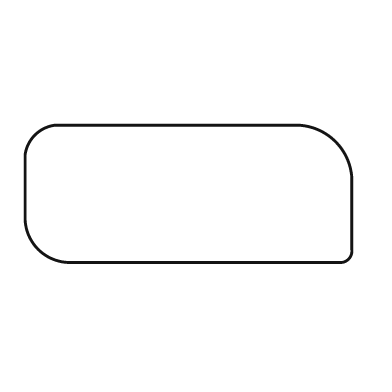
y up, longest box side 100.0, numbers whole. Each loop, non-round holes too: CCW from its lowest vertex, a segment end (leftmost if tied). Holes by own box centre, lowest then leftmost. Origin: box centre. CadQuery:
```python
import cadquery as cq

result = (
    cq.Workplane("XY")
    .moveTo(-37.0, -21.0)
    .lineTo(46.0, -21.0)
    .threePointArc((49.0, -20.0), (50.0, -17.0))
    .lineTo(50.0, 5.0)
    .threePointArc((45.0, 16.0), (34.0, 21.0))
    .lineTo(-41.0, 21.0)
    .threePointArc((-47.0, 18.0), (-50.0, 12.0))
    .lineTo(-50.0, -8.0)
    .threePointArc((-46.0, -17.0), (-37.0, -21.0))
    .close()
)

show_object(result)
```